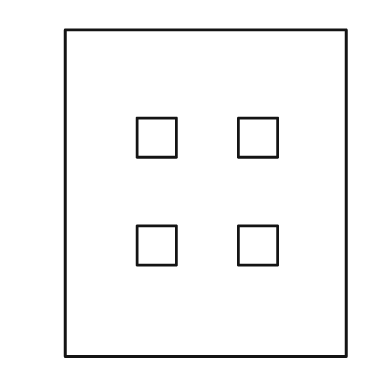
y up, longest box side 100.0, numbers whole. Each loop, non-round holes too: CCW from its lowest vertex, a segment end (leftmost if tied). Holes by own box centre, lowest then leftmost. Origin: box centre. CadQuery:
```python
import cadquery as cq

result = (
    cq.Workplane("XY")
    .moveTo(-43.0, -50.0)
    .lineTo(43.0, -50.0)
    .lineTo(43.0, 50.0)
    .lineTo(-43.0, 50.0)
    .close()
    .moveTo(-21.0, -22.0)
    .lineTo(-9.0, -22.0)
    .lineTo(-9.0, -10.0)
    .lineTo(-21.0, -10.0)
    .close()
    .moveTo(10.0, -22.0)
    .lineTo(22.0, -22.0)
    .lineTo(22.0, -10.0)
    .lineTo(10.0, -10.0)
    .close()
    .moveTo(-21.0, 11.0)
    .lineTo(-9.0, 11.0)
    .lineTo(-9.0, 23.0)
    .lineTo(-21.0, 23.0)
    .close()
    .moveTo(10.0, 11.0)
    .lineTo(22.0, 11.0)
    .lineTo(22.0, 23.0)
    .lineTo(10.0, 23.0)
    .close()
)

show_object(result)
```